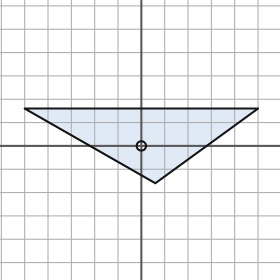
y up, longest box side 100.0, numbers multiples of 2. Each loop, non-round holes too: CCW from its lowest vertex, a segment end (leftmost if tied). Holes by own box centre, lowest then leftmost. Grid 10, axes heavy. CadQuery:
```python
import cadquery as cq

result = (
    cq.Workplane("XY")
    .moveTo(6.0, -16.0)
    .lineTo(50.0, 16.0)
    .lineTo(-50.0, 16.0)
    .close()
    .moveTo(0.0, 0.0)
    .circle(2.0)
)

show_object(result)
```